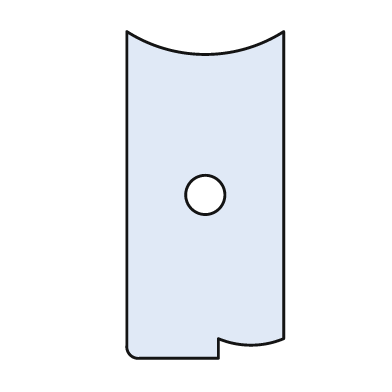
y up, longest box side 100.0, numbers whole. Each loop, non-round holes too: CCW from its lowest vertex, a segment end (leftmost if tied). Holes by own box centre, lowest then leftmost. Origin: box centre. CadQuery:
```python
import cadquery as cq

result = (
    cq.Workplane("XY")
    .moveTo(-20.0, -50.0)
    .lineTo(4.0, -50.0)
    .lineTo(4.0, -44.0)
    .threePointArc((14.0, -46.0), (24.0, -44.0))
    .lineTo(24.0, 50.0)
    .threePointArc((0.0, 43.0), (-24.0, 50.0))
    .lineTo(-24.0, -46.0)
    .threePointArc((-23.0, -49.0), (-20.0, -50.0))
    .close()
    .moveTo(0.0, 0.0)
    .circle(6.0)
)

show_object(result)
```